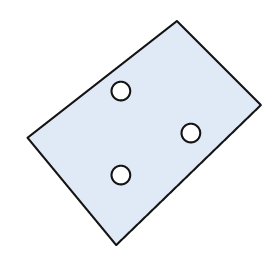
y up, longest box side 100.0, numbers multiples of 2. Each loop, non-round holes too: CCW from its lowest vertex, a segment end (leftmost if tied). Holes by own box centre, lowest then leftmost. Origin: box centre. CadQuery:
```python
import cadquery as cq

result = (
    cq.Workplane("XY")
    .moveTo(-12.0, -48.0)
    .lineTo(50.0, 12.0)
    .lineTo(14.0, 48.0)
    .lineTo(-50.0, -2.0)
    .close()
    .moveTo(-10.0, -18.0)
    .circle(4.0)
    .moveTo(20.0, 0.0)
    .circle(4.0)
    .moveTo(-10.0, 18.0)
    .circle(4.0)
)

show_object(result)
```